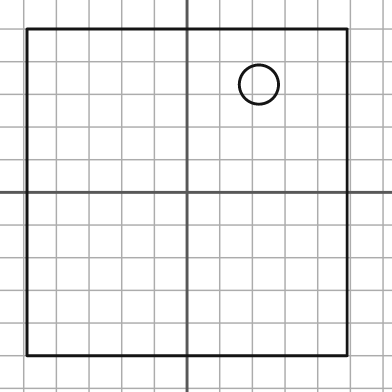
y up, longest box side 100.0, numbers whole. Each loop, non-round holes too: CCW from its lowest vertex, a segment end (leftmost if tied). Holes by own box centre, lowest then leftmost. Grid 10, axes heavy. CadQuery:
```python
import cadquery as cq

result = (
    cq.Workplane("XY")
    .moveTo(-49.0, -50.0)
    .lineTo(49.0, -50.0)
    .lineTo(49.0, 50.0)
    .lineTo(-49.0, 50.0)
    .close()
    .moveTo(22.0, 33.0)
    .circle(6.0)
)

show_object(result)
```